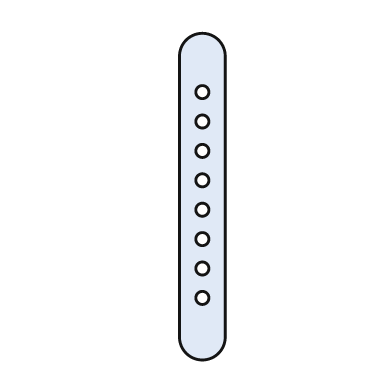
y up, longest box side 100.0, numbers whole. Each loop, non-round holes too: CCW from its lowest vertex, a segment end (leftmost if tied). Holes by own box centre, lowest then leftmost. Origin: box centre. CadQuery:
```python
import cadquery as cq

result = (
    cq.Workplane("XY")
    .moveTo(-7.0, -43.0)
    .threePointArc((0.0, -50.0), (7.0, -43.0))
    .lineTo(7.0, 43.0)
    .threePointArc((0.0, 50.0), (-7.0, 43.0))
    .close()
    .moveTo(0.0, -31.0)
    .circle(2.0)
    .moveTo(0.0, -22.0)
    .circle(2.0)
    .moveTo(0.0, -13.0)
    .circle(2.0)
    .moveTo(0.0, -4.0)
    .circle(2.0)
    .moveTo(0.0, 5.0)
    .circle(2.0)
    .moveTo(0.0, 14.0)
    .circle(2.0)
    .moveTo(0.0, 23.0)
    .circle(2.0)
    .moveTo(0.0, 32.0)
    .circle(2.0)
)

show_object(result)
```